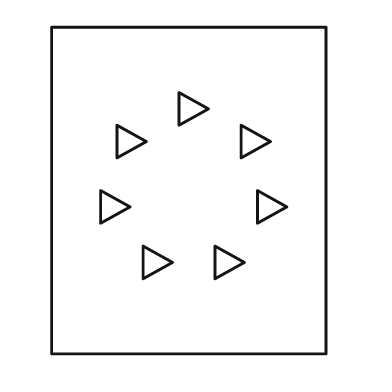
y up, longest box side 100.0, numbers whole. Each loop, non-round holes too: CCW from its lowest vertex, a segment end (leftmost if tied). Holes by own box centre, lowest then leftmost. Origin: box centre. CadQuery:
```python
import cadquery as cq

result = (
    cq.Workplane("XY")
    .moveTo(-42.0, -50.0)
    .lineTo(42.0, -50.0)
    .lineTo(42.0, 50.0)
    .lineTo(-42.0, 50.0)
    .close()
    .moveTo(-14.0, -27.0)
    .lineTo(-5.0, -22.0)
    .lineTo(-14.0, -17.0)
    .close()
    .moveTo(8.0, -27.0)
    .lineTo(17.0, -22.0)
    .lineTo(8.0, -17.0)
    .close()
    .moveTo(-27.0, -10.0)
    .lineTo(-18.0, -5.0)
    .lineTo(-27.0, 0.0)
    .close()
    .moveTo(21.0, -10.0)
    .lineTo(30.0, -5.0)
    .lineTo(21.0, 0.0)
    .close()
    .moveTo(-22.0, 10.0)
    .lineTo(-13.0, 15.0)
    .lineTo(-22.0, 20.0)
    .close()
    .moveTo(16.0, 10.0)
    .lineTo(25.0, 15.0)
    .lineTo(16.0, 20.0)
    .close()
    .moveTo(-3.0, 20.0)
    .lineTo(6.0, 25.0)
    .lineTo(-3.0, 30.0)
    .close()
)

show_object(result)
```